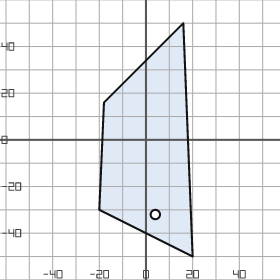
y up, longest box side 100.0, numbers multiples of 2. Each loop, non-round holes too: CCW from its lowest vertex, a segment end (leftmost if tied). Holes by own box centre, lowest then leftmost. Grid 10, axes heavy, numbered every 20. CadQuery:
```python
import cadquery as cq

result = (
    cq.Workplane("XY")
    .moveTo(20.0, -50.0)
    .lineTo(16.0, 50.0)
    .lineTo(-18.0, 16.0)
    .lineTo(-20.0, -30.0)
    .close()
    .moveTo(4.0, -32.0)
    .circle(2.0)
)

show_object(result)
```